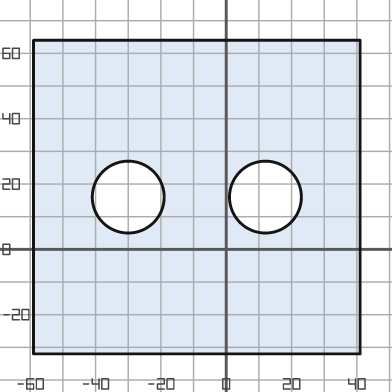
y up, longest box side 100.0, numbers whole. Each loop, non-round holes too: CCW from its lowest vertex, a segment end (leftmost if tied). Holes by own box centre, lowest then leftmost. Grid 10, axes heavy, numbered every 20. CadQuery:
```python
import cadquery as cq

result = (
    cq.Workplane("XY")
    .moveTo(-59.0, -32.0)
    .lineTo(41.0, -32.0)
    .lineTo(41.0, 64.0)
    .lineTo(-59.0, 64.0)
    .close()
    .moveTo(-30.0, 16.0)
    .circle(11.0)
    .moveTo(12.0, 16.0)
    .circle(11.0)
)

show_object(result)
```